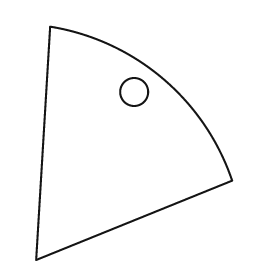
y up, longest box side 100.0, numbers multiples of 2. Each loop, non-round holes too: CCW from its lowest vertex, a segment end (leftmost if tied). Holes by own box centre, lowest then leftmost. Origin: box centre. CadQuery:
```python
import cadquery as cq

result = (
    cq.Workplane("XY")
    .moveTo(-42.0, -50.0)
    .lineTo(42.0, -16.0)
    .threePointArc((12.0, 28.0), (-36.0, 50.0))
    .close()
    .moveTo(0.0, 22.0)
    .circle(6.0)
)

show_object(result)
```